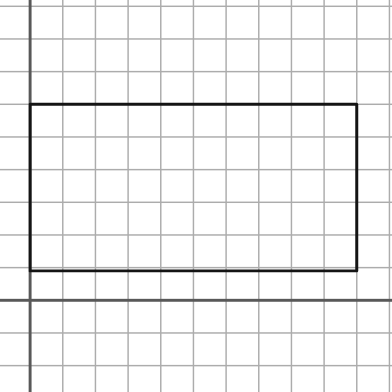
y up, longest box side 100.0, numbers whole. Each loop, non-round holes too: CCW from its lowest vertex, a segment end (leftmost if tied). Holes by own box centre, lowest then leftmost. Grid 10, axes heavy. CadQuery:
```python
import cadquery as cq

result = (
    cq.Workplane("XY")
    .moveTo(0.0, 9.0)
    .lineTo(100.0, 9.0)
    .lineTo(100.0, 60.0)
    .lineTo(0.0, 60.0)
    .close()
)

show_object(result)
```